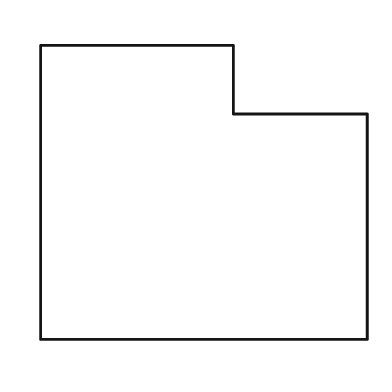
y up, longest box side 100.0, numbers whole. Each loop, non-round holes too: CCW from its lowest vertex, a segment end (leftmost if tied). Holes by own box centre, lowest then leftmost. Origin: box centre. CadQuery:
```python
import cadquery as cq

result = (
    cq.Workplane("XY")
    .moveTo(-50.0, -45.0)
    .lineTo(50.0, -45.0)
    .lineTo(50.0, 24.0)
    .lineTo(9.0, 24.0)
    .lineTo(9.0, 45.0)
    .lineTo(-50.0, 45.0)
    .close()
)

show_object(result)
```